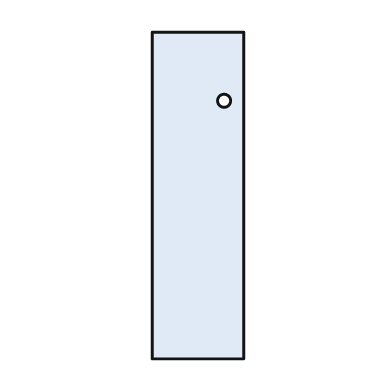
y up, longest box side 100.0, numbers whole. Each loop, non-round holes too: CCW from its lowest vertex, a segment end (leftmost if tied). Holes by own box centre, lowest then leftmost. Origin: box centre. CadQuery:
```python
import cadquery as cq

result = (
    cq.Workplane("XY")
    .moveTo(-14.0, -50.0)
    .lineTo(14.0, -50.0)
    .lineTo(14.0, 50.0)
    .lineTo(-14.0, 50.0)
    .close()
    .moveTo(8.0, 29.0)
    .circle(2.0)
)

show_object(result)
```